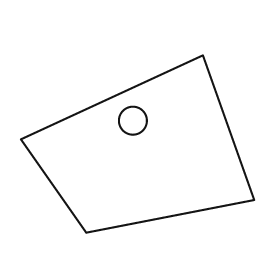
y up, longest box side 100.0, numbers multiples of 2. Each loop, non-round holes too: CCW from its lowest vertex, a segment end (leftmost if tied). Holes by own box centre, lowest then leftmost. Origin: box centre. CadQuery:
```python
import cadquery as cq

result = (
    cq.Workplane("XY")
    .moveTo(-22.0, -38.0)
    .lineTo(50.0, -24.0)
    .lineTo(28.0, 38.0)
    .lineTo(-50.0, 2.0)
    .close()
    .moveTo(-2.0, 10.0)
    .circle(6.0)
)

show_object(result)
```